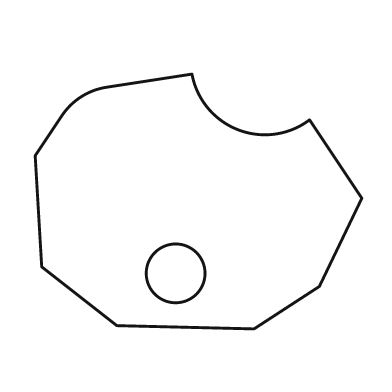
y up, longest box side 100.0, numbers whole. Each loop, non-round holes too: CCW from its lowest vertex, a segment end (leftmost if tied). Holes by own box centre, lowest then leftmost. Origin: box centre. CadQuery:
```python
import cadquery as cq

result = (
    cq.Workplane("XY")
    .moveTo(17.0, -39.0)
    .lineTo(37.0, -26.0)
    .lineTo(50.0, 1.0)
    .lineTo(34.0, 25.0)
    .threePointArc((12.0, 22.0), (-2.0, 39.0))
    .lineTo(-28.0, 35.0)
    .threePointArc((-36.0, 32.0), (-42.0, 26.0))
    .lineTo(-50.0, 14.0)
    .lineTo(-48.0, -20.0)
    .lineTo(-25.0, -38.0)
    .close()
    .moveTo(-7.0, -22.0)
    .circle(9.0)
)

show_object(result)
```